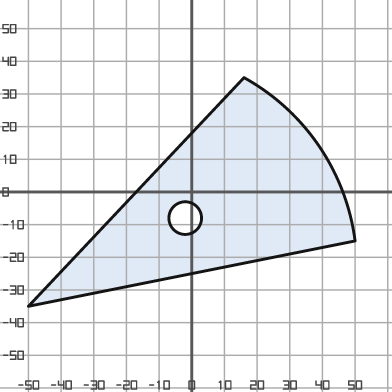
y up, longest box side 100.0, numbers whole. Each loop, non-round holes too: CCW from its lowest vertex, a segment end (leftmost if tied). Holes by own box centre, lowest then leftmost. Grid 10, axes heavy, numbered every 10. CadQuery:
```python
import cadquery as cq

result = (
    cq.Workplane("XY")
    .moveTo(-50.0, -35.0)
    .lineTo(50.0, -15.0)
    .threePointArc((39.0, 14.0), (16.0, 35.0))
    .close()
    .moveTo(-2.0, -8.0)
    .circle(5.0)
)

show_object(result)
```